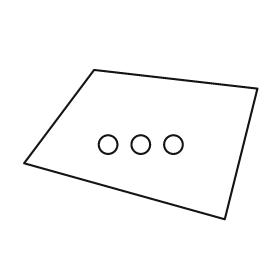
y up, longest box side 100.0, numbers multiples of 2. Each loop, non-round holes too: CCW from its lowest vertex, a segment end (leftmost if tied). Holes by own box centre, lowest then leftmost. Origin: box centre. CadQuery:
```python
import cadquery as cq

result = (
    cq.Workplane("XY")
    .moveTo(36.0, -32.0)
    .lineTo(50.0, 24.0)
    .lineTo(-20.0, 32.0)
    .lineTo(-50.0, -8.0)
    .close()
    .moveTo(-14.0, 0.0)
    .circle(4.0)
    .moveTo(0.0, 0.0)
    .circle(4.0)
    .moveTo(14.0, 0.0)
    .circle(4.0)
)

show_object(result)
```